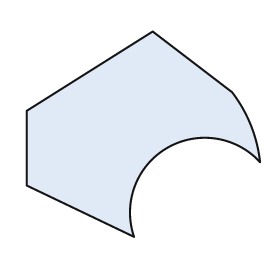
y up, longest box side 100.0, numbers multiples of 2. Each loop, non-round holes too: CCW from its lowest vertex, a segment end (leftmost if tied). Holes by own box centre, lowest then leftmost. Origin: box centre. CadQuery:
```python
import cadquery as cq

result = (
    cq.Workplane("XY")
    .moveTo(-4.0, -44.0)
    .threePointArc((10.0, -6.0), (50.0, -12.0))
    .threePointArc((46.0, 4.0), (38.0, 18.0))
    .lineTo(4.0, 44.0)
    .lineTo(-50.0, 10.0)
    .lineTo(-50.0, -22.0)
    .close()
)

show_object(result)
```